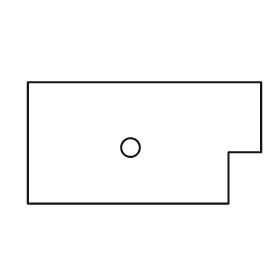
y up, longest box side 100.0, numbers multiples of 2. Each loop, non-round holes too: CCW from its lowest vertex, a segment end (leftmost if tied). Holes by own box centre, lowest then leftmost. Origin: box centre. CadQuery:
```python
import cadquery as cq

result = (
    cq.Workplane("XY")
    .moveTo(-50.0, -26.0)
    .lineTo(36.0, -26.0)
    .lineTo(36.0, -4.0)
    .lineTo(50.0, -4.0)
    .lineTo(50.0, 26.0)
    .lineTo(-50.0, 26.0)
    .close()
    .moveTo(-6.0, -2.0)
    .circle(4.0)
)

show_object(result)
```